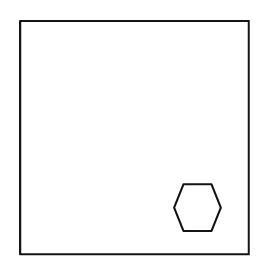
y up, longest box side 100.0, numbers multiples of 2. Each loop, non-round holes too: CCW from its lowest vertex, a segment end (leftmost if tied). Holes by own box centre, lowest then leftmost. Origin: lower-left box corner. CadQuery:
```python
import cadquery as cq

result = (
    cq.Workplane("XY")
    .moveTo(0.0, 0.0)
    .lineTo(98.0, 0.0)
    .lineTo(98.0, 100.0)
    .lineTo(0.0, 100.0)
    .close()
    .moveTo(70.0, 10.0)
    .lineTo(82.0, 10.0)
    .lineTo(86.0, 20.0)
    .lineTo(82.0, 30.0)
    .lineTo(70.0, 30.0)
    .lineTo(66.0, 20.0)
    .close()
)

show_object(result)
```